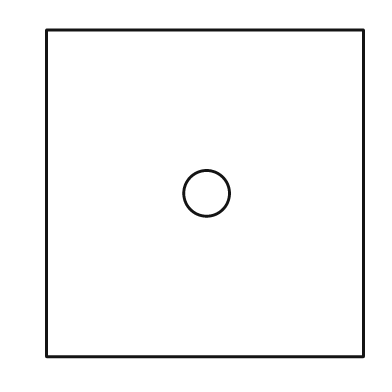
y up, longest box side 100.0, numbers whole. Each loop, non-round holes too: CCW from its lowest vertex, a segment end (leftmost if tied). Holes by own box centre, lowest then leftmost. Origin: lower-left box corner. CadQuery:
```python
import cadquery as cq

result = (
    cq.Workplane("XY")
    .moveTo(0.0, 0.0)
    .lineTo(97.0, 0.0)
    .lineTo(97.0, 100.0)
    .lineTo(0.0, 100.0)
    .close()
    .moveTo(49.0, 50.0)
    .circle(7.0)
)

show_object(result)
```